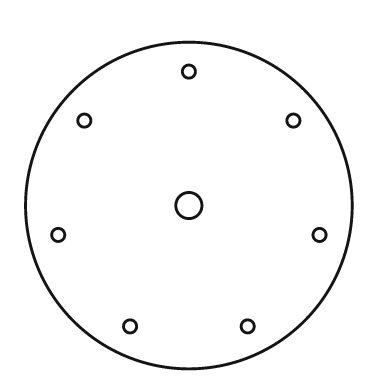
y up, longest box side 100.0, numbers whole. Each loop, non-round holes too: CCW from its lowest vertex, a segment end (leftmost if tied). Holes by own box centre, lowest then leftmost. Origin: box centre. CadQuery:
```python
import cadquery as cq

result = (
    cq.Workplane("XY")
    .moveTo(0.0, 0.0)
    .circle(50.0)
    .moveTo(-18.0, -37.0)
    .circle(2.0)
    .moveTo(18.0, -37.0)
    .circle(2.0)
    .moveTo(-40.0, -9.0)
    .circle(2.0)
    .moveTo(40.0, -9.0)
    .circle(2.0)
    .moveTo(0.0, 0.0)
    .circle(4.0)
    .moveTo(-32.0, 26.0)
    .circle(2.0)
    .moveTo(32.0, 26.0)
    .circle(2.0)
    .moveTo(0.0, 41.0)
    .circle(2.0)
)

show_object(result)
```